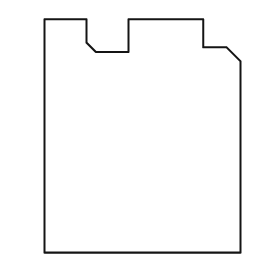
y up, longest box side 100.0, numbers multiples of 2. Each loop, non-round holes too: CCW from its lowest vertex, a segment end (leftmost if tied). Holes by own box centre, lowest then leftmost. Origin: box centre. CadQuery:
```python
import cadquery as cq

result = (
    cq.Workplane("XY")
    .moveTo(-42.0, -50.0)
    .lineTo(42.0, -50.0)
    .lineTo(42.0, 32.0)
    .lineTo(36.0, 38.0)
    .lineTo(26.0, 38.0)
    .lineTo(26.0, 50.0)
    .lineTo(-6.0, 50.0)
    .lineTo(-6.0, 36.0)
    .lineTo(-20.0, 36.0)
    .lineTo(-24.0, 40.0)
    .lineTo(-24.0, 50.0)
    .lineTo(-42.0, 50.0)
    .close()
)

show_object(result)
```